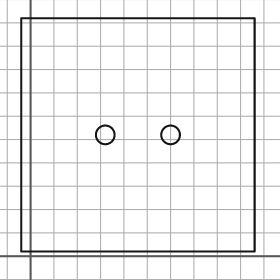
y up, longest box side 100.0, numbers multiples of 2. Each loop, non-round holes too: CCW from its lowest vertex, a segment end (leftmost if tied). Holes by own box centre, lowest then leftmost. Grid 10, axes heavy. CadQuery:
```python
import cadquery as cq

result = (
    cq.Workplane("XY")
    .moveTo(-4.0, 2.0)
    .lineTo(96.0, 2.0)
    .lineTo(96.0, 102.0)
    .lineTo(-4.0, 102.0)
    .close()
    .moveTo(32.0, 52.0)
    .circle(4.0)
    .moveTo(60.0, 52.0)
    .circle(4.0)
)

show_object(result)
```